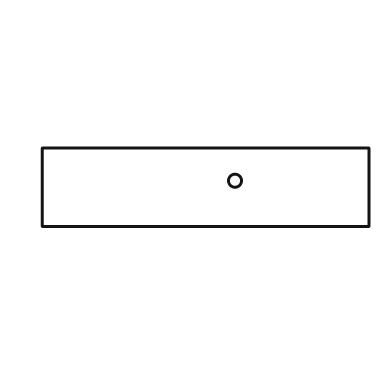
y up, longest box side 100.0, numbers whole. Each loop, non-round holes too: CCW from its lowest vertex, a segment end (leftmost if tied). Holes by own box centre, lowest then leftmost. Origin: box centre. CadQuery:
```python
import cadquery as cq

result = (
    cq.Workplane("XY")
    .moveTo(-50.0, -12.0)
    .lineTo(50.0, -12.0)
    .lineTo(50.0, 12.0)
    .lineTo(-50.0, 12.0)
    .close()
    .moveTo(9.0, 2.0)
    .circle(2.0)
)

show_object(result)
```